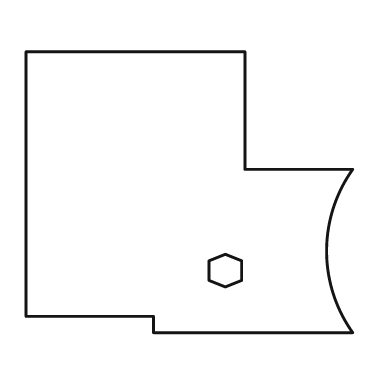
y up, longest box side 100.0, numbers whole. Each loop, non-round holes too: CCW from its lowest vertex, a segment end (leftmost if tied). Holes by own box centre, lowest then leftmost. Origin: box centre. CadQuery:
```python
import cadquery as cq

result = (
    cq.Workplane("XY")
    .moveTo(-11.0, -43.0)
    .lineTo(50.0, -43.0)
    .threePointArc((42.0, -18.0), (50.0, 7.0))
    .lineTo(17.0, 7.0)
    .lineTo(17.0, 43.0)
    .lineTo(-50.0, 43.0)
    .lineTo(-50.0, -38.0)
    .lineTo(-11.0, -38.0)
    .close()
    .moveTo(11.0, -29.0)
    .lineTo(16.0, -27.0)
    .lineTo(16.0, -21.0)
    .lineTo(11.0, -19.0)
    .lineTo(6.0, -21.0)
    .lineTo(6.0, -27.0)
    .close()
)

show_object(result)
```